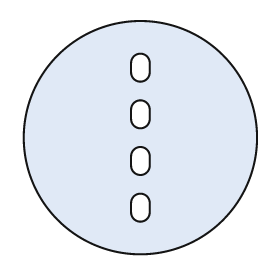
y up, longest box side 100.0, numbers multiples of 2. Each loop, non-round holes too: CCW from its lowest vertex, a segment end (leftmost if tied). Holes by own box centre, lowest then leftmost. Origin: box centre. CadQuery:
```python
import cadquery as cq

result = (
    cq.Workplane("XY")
    .moveTo(0.0, 0.0)
    .circle(50.0)
    .moveTo(-4.0, -32.0)
    .threePointArc((0.0, -36.0), (4.0, -32.0))
    .lineTo(4.0, -28.0)
    .threePointArc((0.0, -24.0), (-4.0, -28.0))
    .close()
    .moveTo(-4.0, -12.0)
    .threePointArc((0.0, -16.0), (4.0, -12.0))
    .lineTo(4.0, -8.0)
    .threePointArc((0.0, -4.0), (-4.0, -8.0))
    .close()
    .moveTo(-4.0, 8.0)
    .threePointArc((0.0, 4.0), (4.0, 8.0))
    .lineTo(4.0, 12.0)
    .threePointArc((0.0, 16.0), (-4.0, 12.0))
    .close()
    .moveTo(-4.0, 28.0)
    .threePointArc((0.0, 24.0), (4.0, 28.0))
    .lineTo(4.0, 32.0)
    .threePointArc((0.0, 36.0), (-4.0, 32.0))
    .close()
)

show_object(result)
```